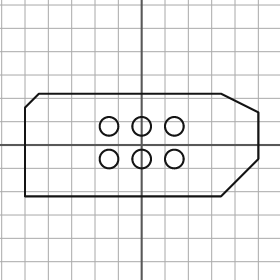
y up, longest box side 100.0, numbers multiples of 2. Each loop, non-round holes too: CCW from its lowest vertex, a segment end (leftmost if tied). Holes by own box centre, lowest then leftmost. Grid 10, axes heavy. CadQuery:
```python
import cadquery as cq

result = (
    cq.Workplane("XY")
    .moveTo(-50.0, -22.0)
    .lineTo(34.0, -22.0)
    .lineTo(50.0, -6.0)
    .lineTo(50.0, 14.0)
    .lineTo(34.0, 22.0)
    .lineTo(-44.0, 22.0)
    .lineTo(-50.0, 16.0)
    .close()
    .moveTo(-14.0, -6.0)
    .circle(4.0)
    .moveTo(0.0, -6.0)
    .circle(4.0)
    .moveTo(14.0, -6.0)
    .circle(4.0)
    .moveTo(-14.0, 8.0)
    .circle(4.0)
    .moveTo(0.0, 8.0)
    .circle(4.0)
    .moveTo(14.0, 8.0)
    .circle(4.0)
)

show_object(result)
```